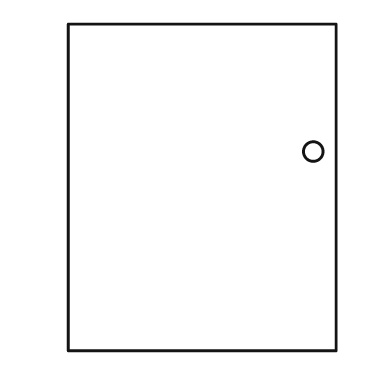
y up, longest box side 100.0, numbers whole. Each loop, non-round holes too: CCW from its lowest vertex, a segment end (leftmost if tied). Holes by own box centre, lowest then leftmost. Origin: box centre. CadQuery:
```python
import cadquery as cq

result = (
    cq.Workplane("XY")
    .moveTo(-41.0, -50.0)
    .lineTo(41.0, -50.0)
    .lineTo(41.0, 50.0)
    .lineTo(-41.0, 50.0)
    .close()
    .moveTo(34.0, 11.0)
    .circle(3.0)
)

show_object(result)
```